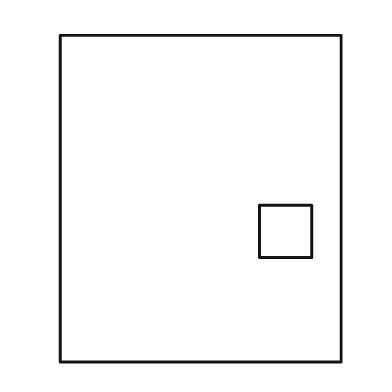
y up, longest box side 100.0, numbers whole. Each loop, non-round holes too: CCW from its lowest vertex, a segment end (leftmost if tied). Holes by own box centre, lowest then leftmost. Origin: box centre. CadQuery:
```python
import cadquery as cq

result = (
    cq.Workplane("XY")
    .moveTo(-43.0, -50.0)
    .lineTo(43.0, -50.0)
    .lineTo(43.0, 50.0)
    .lineTo(-43.0, 50.0)
    .close()
    .moveTo(18.0, -18.0)
    .lineTo(34.0, -18.0)
    .lineTo(34.0, -2.0)
    .lineTo(18.0, -2.0)
    .close()
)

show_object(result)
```